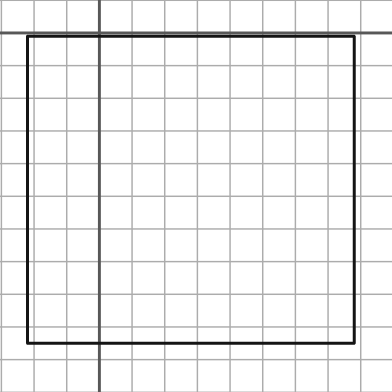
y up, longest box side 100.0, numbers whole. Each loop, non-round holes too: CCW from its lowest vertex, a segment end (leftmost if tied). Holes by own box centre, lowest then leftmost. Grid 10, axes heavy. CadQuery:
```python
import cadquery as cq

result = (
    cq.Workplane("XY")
    .moveTo(-22.0, -95.0)
    .lineTo(78.0, -95.0)
    .lineTo(78.0, -1.0)
    .lineTo(-22.0, -1.0)
    .close()
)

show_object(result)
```